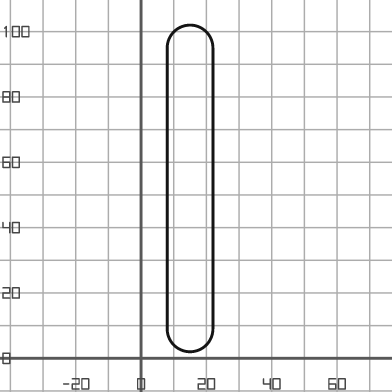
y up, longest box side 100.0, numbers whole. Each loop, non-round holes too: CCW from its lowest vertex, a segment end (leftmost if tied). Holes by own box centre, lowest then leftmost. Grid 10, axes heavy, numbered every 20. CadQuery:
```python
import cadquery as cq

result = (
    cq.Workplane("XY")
    .moveTo(8.0, 9.0)
    .threePointArc((15.0, 2.0), (22.0, 9.0))
    .lineTo(22.0, 95.0)
    .threePointArc((15.0, 102.0), (8.0, 95.0))
    .close()
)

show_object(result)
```